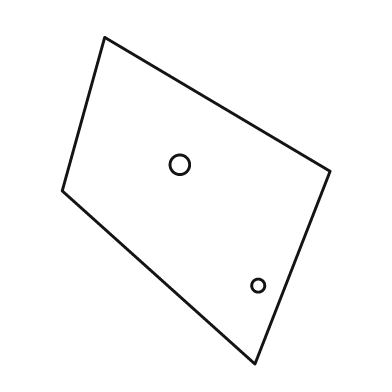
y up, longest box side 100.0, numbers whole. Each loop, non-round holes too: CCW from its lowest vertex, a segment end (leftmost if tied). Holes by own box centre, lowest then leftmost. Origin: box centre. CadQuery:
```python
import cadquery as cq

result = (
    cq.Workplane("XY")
    .moveTo(18.0, -50.0)
    .lineTo(41.0, 9.0)
    .lineTo(-28.0, 50.0)
    .lineTo(-41.0, 3.0)
    .close()
    .moveTo(19.0, -26.0)
    .circle(2.0)
    .moveTo(-5.0, 11.0)
    .circle(3.0)
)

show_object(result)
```